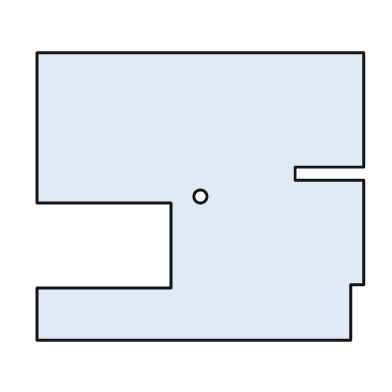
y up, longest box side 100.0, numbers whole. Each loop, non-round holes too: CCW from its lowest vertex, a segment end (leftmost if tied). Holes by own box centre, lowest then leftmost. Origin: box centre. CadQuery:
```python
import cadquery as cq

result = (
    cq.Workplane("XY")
    .moveTo(-50.0, -44.0)
    .lineTo(46.0, -44.0)
    .lineTo(46.0, -27.0)
    .lineTo(50.0, -27.0)
    .lineTo(50.0, 5.0)
    .lineTo(29.0, 5.0)
    .lineTo(29.0, 9.0)
    .lineTo(50.0, 9.0)
    .lineTo(50.0, 44.0)
    .lineTo(-50.0, 44.0)
    .lineTo(-50.0, -2.0)
    .lineTo(-9.0, -2.0)
    .lineTo(-9.0, -28.0)
    .lineTo(-50.0, -28.0)
    .close()
    .moveTo(0.0, 0.0)
    .circle(2.0)
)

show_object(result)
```